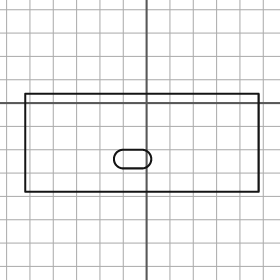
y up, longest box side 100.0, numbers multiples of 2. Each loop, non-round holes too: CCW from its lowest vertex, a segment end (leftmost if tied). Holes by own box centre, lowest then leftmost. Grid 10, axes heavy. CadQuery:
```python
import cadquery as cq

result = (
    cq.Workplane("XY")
    .moveTo(-52.0, -38.0)
    .lineTo(48.0, -38.0)
    .lineTo(48.0, 4.0)
    .lineTo(-52.0, 4.0)
    .close()
    .moveTo(-10.0, -28.0)
    .lineTo(-2.0, -28.0)
    .threePointArc((2.0, -24.0), (-2.0, -20.0))
    .lineTo(-10.0, -20.0)
    .threePointArc((-14.0, -24.0), (-10.0, -28.0))
    .close()
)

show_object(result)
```